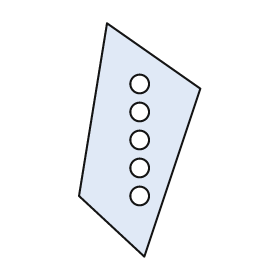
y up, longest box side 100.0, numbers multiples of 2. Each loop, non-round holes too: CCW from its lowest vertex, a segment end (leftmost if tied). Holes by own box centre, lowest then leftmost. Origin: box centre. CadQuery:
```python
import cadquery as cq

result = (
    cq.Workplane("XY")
    .moveTo(2.0, -50.0)
    .lineTo(26.0, 22.0)
    .lineTo(-14.0, 50.0)
    .lineTo(-26.0, -24.0)
    .close()
    .moveTo(0.0, -24.0)
    .circle(4.0)
    .moveTo(0.0, -12.0)
    .circle(4.0)
    .moveTo(0.0, 0.0)
    .circle(4.0)
    .moveTo(0.0, 12.0)
    .circle(4.0)
    .moveTo(0.0, 24.0)
    .circle(4.0)
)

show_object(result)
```